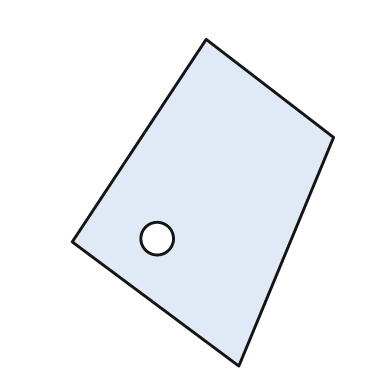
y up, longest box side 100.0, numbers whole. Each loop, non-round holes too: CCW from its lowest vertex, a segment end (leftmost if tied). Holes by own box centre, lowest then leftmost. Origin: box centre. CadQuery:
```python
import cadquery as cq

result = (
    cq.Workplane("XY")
    .moveTo(11.0, -50.0)
    .lineTo(40.0, 20.0)
    .lineTo(1.0, 50.0)
    .lineTo(-40.0, -12.0)
    .close()
    .moveTo(-14.0, -11.0)
    .circle(5.0)
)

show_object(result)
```